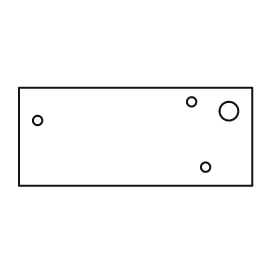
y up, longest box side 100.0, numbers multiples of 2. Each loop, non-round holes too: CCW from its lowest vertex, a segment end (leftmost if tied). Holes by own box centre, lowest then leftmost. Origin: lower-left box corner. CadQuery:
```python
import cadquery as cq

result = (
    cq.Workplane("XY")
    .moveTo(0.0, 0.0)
    .lineTo(100.0, 0.0)
    .lineTo(100.0, 42.0)
    .lineTo(0.0, 42.0)
    .close()
    .moveTo(80.0, 8.0)
    .circle(2.0)
    .moveTo(8.0, 28.0)
    .circle(2.0)
    .moveTo(90.0, 32.0)
    .circle(4.0)
    .moveTo(74.0, 36.0)
    .circle(2.0)
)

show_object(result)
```